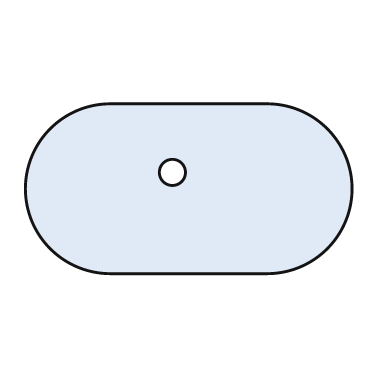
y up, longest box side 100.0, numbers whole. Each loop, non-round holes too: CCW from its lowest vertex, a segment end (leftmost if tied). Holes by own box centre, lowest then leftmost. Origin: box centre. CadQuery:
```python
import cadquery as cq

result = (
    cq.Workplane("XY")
    .moveTo(-24.0, -26.0)
    .lineTo(24.0, -26.0)
    .threePointArc((50.0, 0.0), (24.0, 26.0))
    .lineTo(-24.0, 26.0)
    .threePointArc((-50.0, 0.0), (-24.0, -26.0))
    .close()
    .moveTo(-5.0, 5.0)
    .circle(4.0)
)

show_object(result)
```